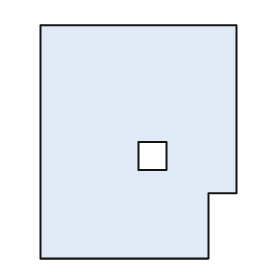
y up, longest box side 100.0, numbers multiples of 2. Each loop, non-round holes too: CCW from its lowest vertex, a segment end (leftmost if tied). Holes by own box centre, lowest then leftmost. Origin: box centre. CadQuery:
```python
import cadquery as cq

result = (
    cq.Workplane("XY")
    .moveTo(-42.0, -50.0)
    .lineTo(30.0, -50.0)
    .lineTo(30.0, -22.0)
    .lineTo(42.0, -22.0)
    .lineTo(42.0, 50.0)
    .lineTo(-42.0, 50.0)
    .close()
    .moveTo(0.0, -12.0)
    .lineTo(12.0, -12.0)
    .lineTo(12.0, 0.0)
    .lineTo(0.0, 0.0)
    .close()
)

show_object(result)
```